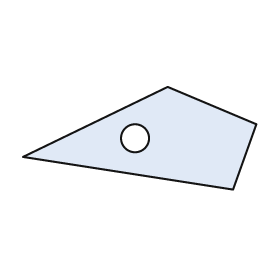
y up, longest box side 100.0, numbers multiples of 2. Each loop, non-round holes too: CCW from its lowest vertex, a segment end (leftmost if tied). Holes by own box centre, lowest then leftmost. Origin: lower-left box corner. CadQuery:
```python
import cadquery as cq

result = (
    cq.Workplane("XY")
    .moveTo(90.0, 0.0)
    .lineTo(100.0, 28.0)
    .lineTo(62.0, 44.0)
    .lineTo(0.0, 14.0)
    .close()
    .moveTo(48.0, 22.0)
    .circle(6.0)
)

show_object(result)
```